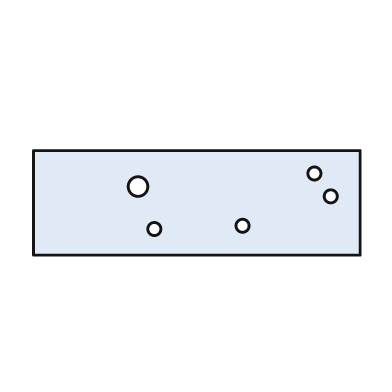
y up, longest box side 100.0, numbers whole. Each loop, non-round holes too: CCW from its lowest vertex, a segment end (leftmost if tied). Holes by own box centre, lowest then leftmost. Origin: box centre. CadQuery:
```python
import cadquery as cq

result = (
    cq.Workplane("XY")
    .moveTo(-50.0, -16.0)
    .lineTo(50.0, -16.0)
    .lineTo(50.0, 16.0)
    .lineTo(-50.0, 16.0)
    .close()
    .moveTo(-13.0, -8.0)
    .circle(2.0)
    .moveTo(14.0, -7.0)
    .circle(2.0)
    .moveTo(41.0, 2.0)
    .circle(2.0)
    .moveTo(-18.0, 5.0)
    .circle(3.0)
    .moveTo(36.0, 9.0)
    .circle(2.0)
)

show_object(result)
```